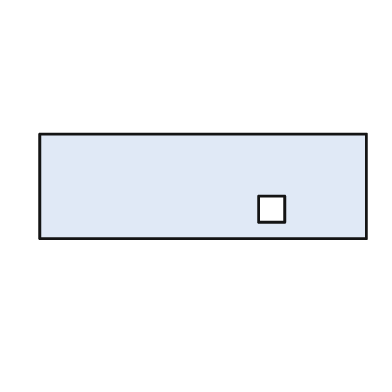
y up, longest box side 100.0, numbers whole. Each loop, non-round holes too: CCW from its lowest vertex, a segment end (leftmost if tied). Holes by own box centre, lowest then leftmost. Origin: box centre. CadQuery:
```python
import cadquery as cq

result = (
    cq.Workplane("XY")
    .moveTo(-50.0, -16.0)
    .lineTo(50.0, -16.0)
    .lineTo(50.0, 16.0)
    .lineTo(-50.0, 16.0)
    .close()
    .moveTo(17.0, -11.0)
    .lineTo(25.0, -11.0)
    .lineTo(25.0, -3.0)
    .lineTo(17.0, -3.0)
    .close()
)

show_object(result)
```